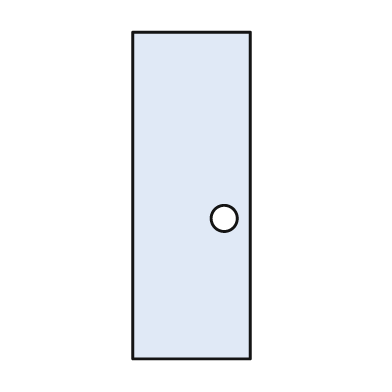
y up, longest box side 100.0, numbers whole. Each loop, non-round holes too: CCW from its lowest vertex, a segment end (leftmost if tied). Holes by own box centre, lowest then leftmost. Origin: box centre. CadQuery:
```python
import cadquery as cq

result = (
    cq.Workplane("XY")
    .moveTo(-18.0, -50.0)
    .lineTo(18.0, -50.0)
    .lineTo(18.0, 50.0)
    .lineTo(-18.0, 50.0)
    .close()
    .moveTo(10.0, -7.0)
    .circle(4.0)
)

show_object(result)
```